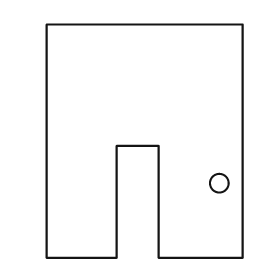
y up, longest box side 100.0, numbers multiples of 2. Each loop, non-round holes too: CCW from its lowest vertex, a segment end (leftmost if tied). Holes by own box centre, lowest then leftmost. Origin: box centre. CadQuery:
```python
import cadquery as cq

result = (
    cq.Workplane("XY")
    .moveTo(-42.0, -50.0)
    .lineTo(-12.0, -50.0)
    .lineTo(-12.0, -2.0)
    .lineTo(6.0, -2.0)
    .lineTo(6.0, -50.0)
    .lineTo(42.0, -50.0)
    .lineTo(42.0, 50.0)
    .lineTo(-42.0, 50.0)
    .close()
    .moveTo(32.0, -18.0)
    .circle(4.0)
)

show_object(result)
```